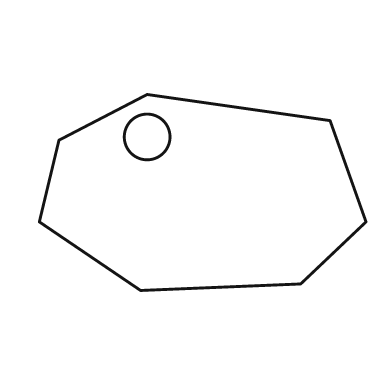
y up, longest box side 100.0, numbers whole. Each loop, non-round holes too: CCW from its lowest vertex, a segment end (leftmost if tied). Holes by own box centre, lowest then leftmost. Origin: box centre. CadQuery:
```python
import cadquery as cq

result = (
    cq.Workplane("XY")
    .moveTo(-19.0, -30.0)
    .lineTo(30.0, -28.0)
    .lineTo(50.0, -9.0)
    .lineTo(39.0, 22.0)
    .lineTo(-17.0, 30.0)
    .lineTo(-44.0, 16.0)
    .lineTo(-50.0, -9.0)
    .close()
    .moveTo(-17.0, 17.0)
    .circle(7.0)
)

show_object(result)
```